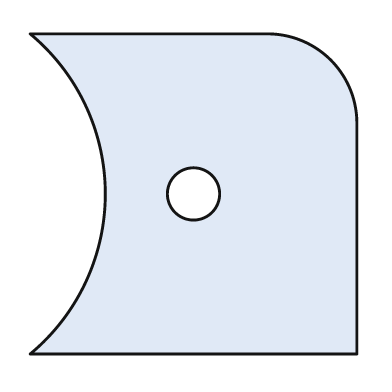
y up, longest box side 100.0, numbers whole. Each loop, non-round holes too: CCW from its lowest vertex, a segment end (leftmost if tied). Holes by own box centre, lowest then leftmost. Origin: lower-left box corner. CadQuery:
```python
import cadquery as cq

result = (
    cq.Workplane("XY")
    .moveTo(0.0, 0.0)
    .lineTo(100.0, 0.0)
    .lineTo(100.0, 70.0)
    .threePointArc((92.0, 90.0), (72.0, 98.0))
    .lineTo(0.0, 98.0)
    .threePointArc((23.0, 49.0), (0.0, 0.0))
    .close()
    .moveTo(50.0, 49.0)
    .circle(8.0)
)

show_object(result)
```